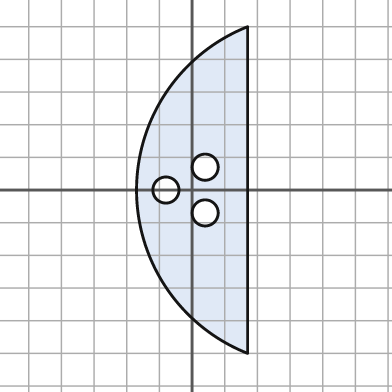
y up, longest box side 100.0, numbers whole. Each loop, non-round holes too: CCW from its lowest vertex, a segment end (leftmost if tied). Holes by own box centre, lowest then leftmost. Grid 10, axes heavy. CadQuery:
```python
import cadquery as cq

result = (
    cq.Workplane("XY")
    .moveTo(17.0, -50.0)
    .lineTo(17.0, 50.0)
    .threePointArc((-17.0, 0.0), (17.0, -50.0))
    .close()
    .moveTo(4.0, -7.0)
    .circle(4.0)
    .moveTo(-8.0, 0.0)
    .circle(4.0)
    .moveTo(4.0, 7.0)
    .circle(4.0)
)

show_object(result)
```